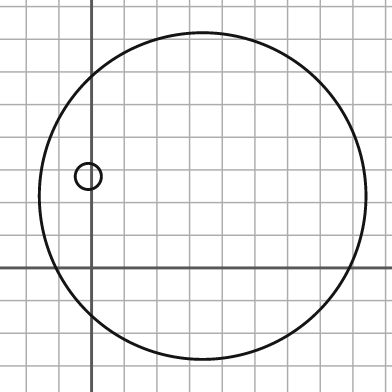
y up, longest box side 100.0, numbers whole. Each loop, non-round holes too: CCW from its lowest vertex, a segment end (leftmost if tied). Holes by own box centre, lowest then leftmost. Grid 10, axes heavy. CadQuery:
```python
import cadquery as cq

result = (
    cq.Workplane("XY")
    .moveTo(34.0, 22.0)
    .circle(50.0)
    .moveTo(-1.0, 28.0)
    .circle(4.0)
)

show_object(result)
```